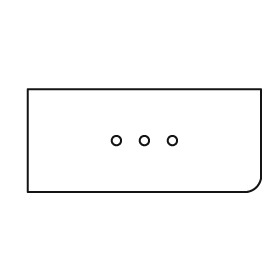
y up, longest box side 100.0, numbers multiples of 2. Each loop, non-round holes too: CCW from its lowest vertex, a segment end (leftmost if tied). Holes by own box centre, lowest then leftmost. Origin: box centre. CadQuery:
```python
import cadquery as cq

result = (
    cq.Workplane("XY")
    .moveTo(-50.0, -22.0)
    .lineTo(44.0, -22.0)
    .threePointArc((48.0, -20.0), (50.0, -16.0))
    .lineTo(50.0, 22.0)
    .lineTo(-50.0, 22.0)
    .close()
    .moveTo(-12.0, 0.0)
    .circle(2.0)
    .moveTo(0.0, 0.0)
    .circle(2.0)
    .moveTo(12.0, 0.0)
    .circle(2.0)
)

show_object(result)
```